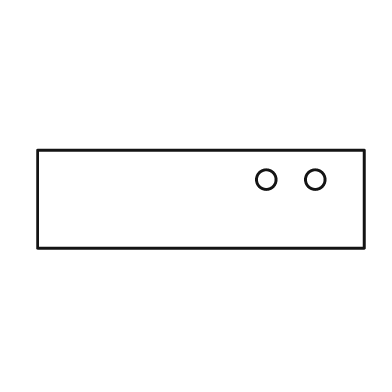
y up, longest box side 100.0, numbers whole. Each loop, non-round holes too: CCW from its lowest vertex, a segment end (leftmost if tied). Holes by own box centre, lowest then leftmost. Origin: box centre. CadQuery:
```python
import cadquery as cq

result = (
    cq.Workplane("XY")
    .moveTo(-50.0, -15.0)
    .lineTo(50.0, -15.0)
    .lineTo(50.0, 15.0)
    .lineTo(-50.0, 15.0)
    .close()
    .moveTo(20.0, 6.0)
    .circle(3.0)
    .moveTo(35.0, 6.0)
    .circle(3.0)
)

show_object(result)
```